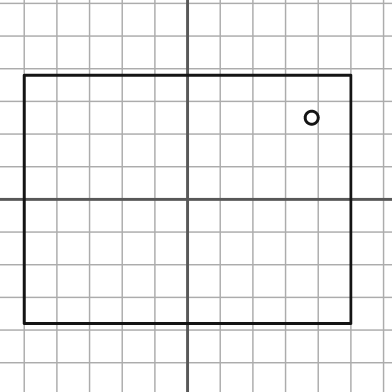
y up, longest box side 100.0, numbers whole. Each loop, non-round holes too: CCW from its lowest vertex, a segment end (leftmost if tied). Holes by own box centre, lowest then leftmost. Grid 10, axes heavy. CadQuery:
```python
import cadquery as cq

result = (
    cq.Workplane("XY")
    .moveTo(-50.0, -38.0)
    .lineTo(50.0, -38.0)
    .lineTo(50.0, 38.0)
    .lineTo(-50.0, 38.0)
    .close()
    .moveTo(38.0, 25.0)
    .circle(2.0)
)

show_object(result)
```